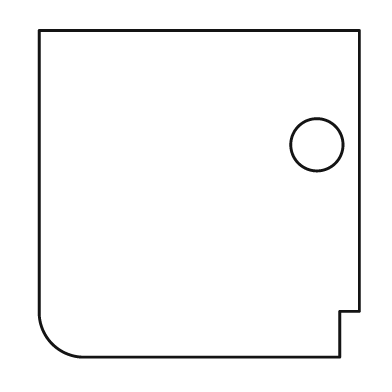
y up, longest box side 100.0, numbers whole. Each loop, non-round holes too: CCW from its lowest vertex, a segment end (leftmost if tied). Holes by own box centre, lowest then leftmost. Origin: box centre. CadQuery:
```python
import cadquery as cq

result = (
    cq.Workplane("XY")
    .moveTo(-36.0, -50.0)
    .lineTo(43.0, -50.0)
    .lineTo(43.0, -36.0)
    .lineTo(49.0, -36.0)
    .lineTo(49.0, 50.0)
    .lineTo(-49.0, 50.0)
    .lineTo(-49.0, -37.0)
    .threePointArc((-45.0, -46.0), (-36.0, -50.0))
    .close()
    .moveTo(36.0, 15.0)
    .circle(8.0)
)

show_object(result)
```